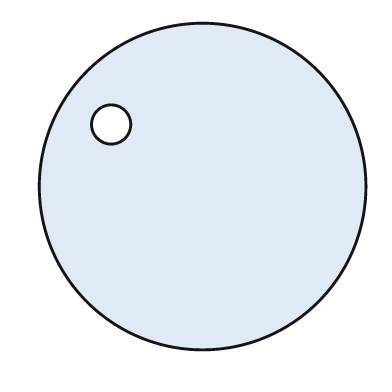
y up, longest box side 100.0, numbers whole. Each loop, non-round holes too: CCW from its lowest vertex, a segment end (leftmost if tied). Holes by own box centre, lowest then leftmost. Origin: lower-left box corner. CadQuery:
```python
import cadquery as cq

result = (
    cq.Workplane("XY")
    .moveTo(50.0, 50.0)
    .circle(50.0)
    .moveTo(22.0, 69.0)
    .circle(6.0)
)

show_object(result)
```